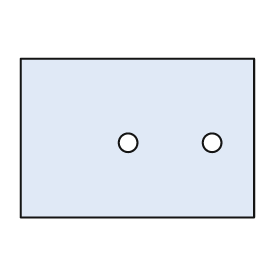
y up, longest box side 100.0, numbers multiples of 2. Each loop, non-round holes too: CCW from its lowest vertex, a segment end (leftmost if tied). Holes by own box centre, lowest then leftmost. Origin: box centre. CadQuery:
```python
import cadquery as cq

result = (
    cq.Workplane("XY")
    .moveTo(-50.0, -34.0)
    .lineTo(50.0, -34.0)
    .lineTo(50.0, 34.0)
    .lineTo(-50.0, 34.0)
    .close()
    .moveTo(-4.0, -2.0)
    .circle(4.0)
    .moveTo(32.0, -2.0)
    .circle(4.0)
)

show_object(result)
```